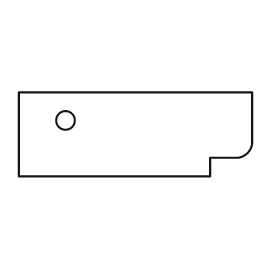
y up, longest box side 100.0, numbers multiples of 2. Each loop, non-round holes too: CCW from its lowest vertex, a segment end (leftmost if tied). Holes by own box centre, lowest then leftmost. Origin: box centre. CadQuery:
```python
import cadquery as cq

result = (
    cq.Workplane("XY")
    .moveTo(-50.0, -18.0)
    .lineTo(32.0, -18.0)
    .lineTo(32.0, -10.0)
    .lineTo(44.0, -10.0)
    .threePointArc((48.0, -8.0), (50.0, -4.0))
    .lineTo(50.0, 18.0)
    .lineTo(-50.0, 18.0)
    .close()
    .moveTo(-30.0, 6.0)
    .circle(4.0)
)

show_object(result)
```